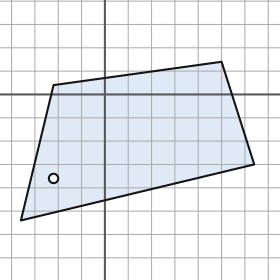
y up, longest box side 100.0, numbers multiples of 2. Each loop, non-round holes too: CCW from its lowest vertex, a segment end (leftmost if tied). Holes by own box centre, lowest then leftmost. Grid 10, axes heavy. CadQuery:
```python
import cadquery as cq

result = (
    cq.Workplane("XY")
    .moveTo(-36.0, -54.0)
    .lineTo(64.0, -30.0)
    .lineTo(50.0, 14.0)
    .lineTo(-22.0, 4.0)
    .close()
    .moveTo(-22.0, -36.0)
    .circle(2.0)
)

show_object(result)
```